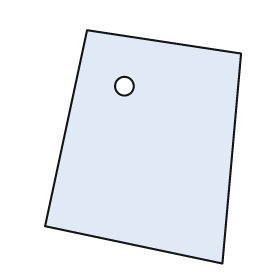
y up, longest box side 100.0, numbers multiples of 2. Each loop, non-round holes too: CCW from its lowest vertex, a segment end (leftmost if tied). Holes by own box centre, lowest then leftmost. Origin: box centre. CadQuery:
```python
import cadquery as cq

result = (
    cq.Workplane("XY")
    .moveTo(34.0, -50.0)
    .lineTo(42.0, 40.0)
    .lineTo(-24.0, 50.0)
    .lineTo(-42.0, -34.0)
    .close()
    .moveTo(-8.0, 26.0)
    .circle(4.0)
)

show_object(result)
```